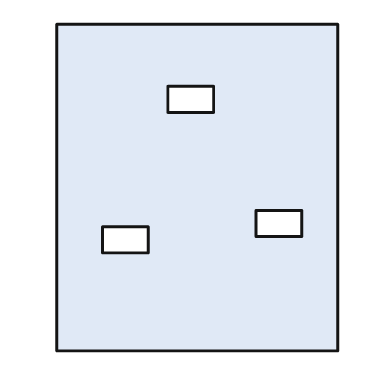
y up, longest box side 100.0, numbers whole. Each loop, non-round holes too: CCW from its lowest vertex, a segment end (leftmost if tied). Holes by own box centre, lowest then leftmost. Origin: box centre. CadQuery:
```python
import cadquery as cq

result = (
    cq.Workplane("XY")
    .moveTo(-43.0, -50.0)
    .lineTo(43.0, -50.0)
    .lineTo(43.0, 50.0)
    .lineTo(-43.0, 50.0)
    .close()
    .moveTo(-29.0, -20.0)
    .lineTo(-15.0, -20.0)
    .lineTo(-15.0, -12.0)
    .lineTo(-29.0, -12.0)
    .close()
    .moveTo(18.0, -15.0)
    .lineTo(32.0, -15.0)
    .lineTo(32.0, -7.0)
    .lineTo(18.0, -7.0)
    .close()
    .moveTo(-9.0, 23.0)
    .lineTo(5.0, 23.0)
    .lineTo(5.0, 31.0)
    .lineTo(-9.0, 31.0)
    .close()
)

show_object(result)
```